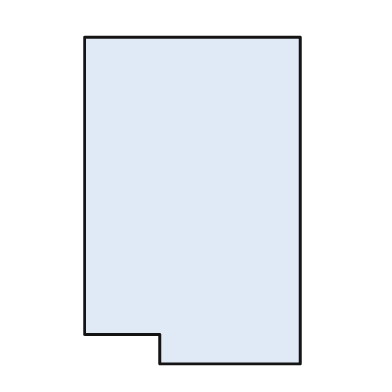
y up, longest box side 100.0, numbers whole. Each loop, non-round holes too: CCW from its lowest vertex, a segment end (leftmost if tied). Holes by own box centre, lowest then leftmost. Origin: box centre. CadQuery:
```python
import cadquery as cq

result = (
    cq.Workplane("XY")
    .moveTo(-10.0, -50.0)
    .lineTo(33.0, -50.0)
    .lineTo(33.0, 50.0)
    .lineTo(-33.0, 50.0)
    .lineTo(-33.0, -41.0)
    .lineTo(-10.0, -41.0)
    .close()
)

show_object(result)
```